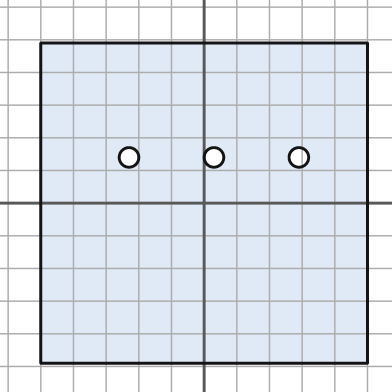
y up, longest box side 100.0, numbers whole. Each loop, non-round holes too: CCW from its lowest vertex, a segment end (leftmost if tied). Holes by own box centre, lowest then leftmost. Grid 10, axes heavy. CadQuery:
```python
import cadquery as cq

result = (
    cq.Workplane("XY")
    .moveTo(-50.0, -49.0)
    .lineTo(50.0, -49.0)
    .lineTo(50.0, 49.0)
    .lineTo(-50.0, 49.0)
    .close()
    .moveTo(-23.0, 14.0)
    .circle(3.0)
    .moveTo(3.0, 14.0)
    .circle(3.0)
    .moveTo(29.0, 14.0)
    .circle(3.0)
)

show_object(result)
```